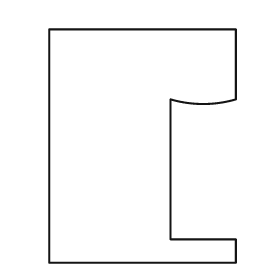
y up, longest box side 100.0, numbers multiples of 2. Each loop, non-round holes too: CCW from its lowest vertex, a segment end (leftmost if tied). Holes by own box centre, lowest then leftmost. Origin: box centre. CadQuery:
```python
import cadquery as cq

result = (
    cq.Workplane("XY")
    .moveTo(-40.0, -50.0)
    .lineTo(40.0, -50.0)
    .lineTo(40.0, -40.0)
    .lineTo(12.0, -40.0)
    .lineTo(12.0, 20.0)
    .threePointArc((26.0, 18.0), (40.0, 20.0))
    .lineTo(40.0, 50.0)
    .lineTo(-40.0, 50.0)
    .close()
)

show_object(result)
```